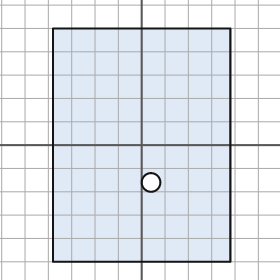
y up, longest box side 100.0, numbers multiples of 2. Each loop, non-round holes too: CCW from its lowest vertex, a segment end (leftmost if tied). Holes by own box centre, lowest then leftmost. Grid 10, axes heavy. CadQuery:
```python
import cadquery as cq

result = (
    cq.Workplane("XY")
    .moveTo(-38.0, -50.0)
    .lineTo(38.0, -50.0)
    .lineTo(38.0, 50.0)
    .lineTo(-38.0, 50.0)
    .close()
    .moveTo(4.0, -16.0)
    .circle(4.0)
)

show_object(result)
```